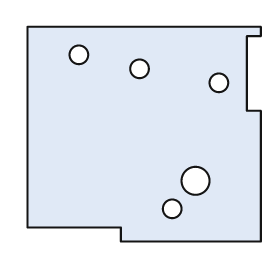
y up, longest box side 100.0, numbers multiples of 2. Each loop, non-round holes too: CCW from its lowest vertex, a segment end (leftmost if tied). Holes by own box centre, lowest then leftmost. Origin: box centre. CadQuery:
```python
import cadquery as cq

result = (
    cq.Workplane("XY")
    .moveTo(-10.0, -46.0)
    .lineTo(50.0, -46.0)
    .lineTo(50.0, 10.0)
    .lineTo(44.0, 10.0)
    .lineTo(44.0, 42.0)
    .lineTo(50.0, 42.0)
    .lineTo(50.0, 46.0)
    .lineTo(-50.0, 46.0)
    .lineTo(-50.0, -40.0)
    .lineTo(-10.0, -40.0)
    .close()
    .moveTo(12.0, -32.0)
    .circle(4.0)
    .moveTo(22.0, -20.0)
    .circle(6.0)
    .moveTo(32.0, 22.0)
    .circle(4.0)
    .moveTo(-2.0, 28.0)
    .circle(4.0)
    .moveTo(-28.0, 34.0)
    .circle(4.0)
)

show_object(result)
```